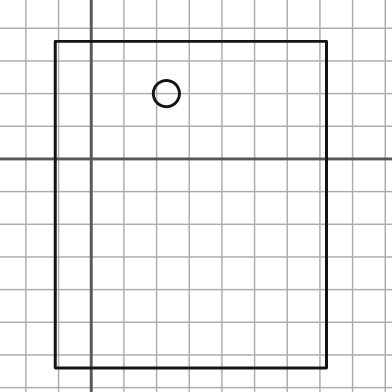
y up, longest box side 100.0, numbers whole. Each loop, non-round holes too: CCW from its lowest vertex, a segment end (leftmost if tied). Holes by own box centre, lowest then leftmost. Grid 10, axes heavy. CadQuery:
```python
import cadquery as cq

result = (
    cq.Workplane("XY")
    .moveTo(-11.0, -64.0)
    .lineTo(72.0, -64.0)
    .lineTo(72.0, 36.0)
    .lineTo(-11.0, 36.0)
    .close()
    .moveTo(23.0, 20.0)
    .circle(4.0)
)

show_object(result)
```